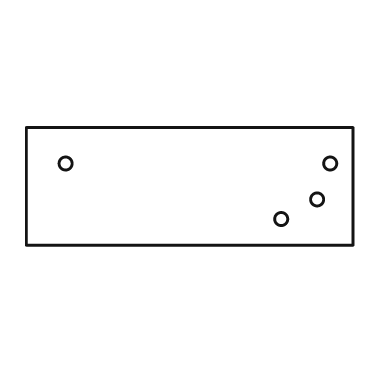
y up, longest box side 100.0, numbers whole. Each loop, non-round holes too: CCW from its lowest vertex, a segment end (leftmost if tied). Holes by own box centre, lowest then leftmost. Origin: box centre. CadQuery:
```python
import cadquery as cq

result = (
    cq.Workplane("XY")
    .moveTo(-50.0, -18.0)
    .lineTo(50.0, -18.0)
    .lineTo(50.0, 18.0)
    .lineTo(-50.0, 18.0)
    .close()
    .moveTo(28.0, -10.0)
    .circle(2.0)
    .moveTo(39.0, -4.0)
    .circle(2.0)
    .moveTo(-38.0, 7.0)
    .circle(2.0)
    .moveTo(43.0, 7.0)
    .circle(2.0)
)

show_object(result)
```